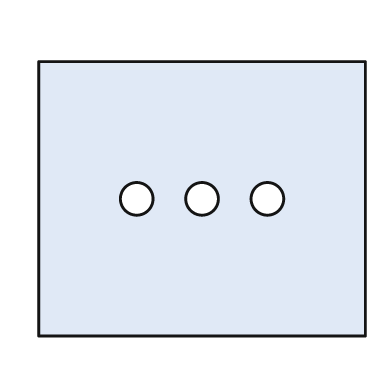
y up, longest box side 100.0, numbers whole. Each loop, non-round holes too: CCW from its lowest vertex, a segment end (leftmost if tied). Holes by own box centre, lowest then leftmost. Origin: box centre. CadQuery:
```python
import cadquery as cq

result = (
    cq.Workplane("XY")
    .moveTo(-50.0, -42.0)
    .lineTo(50.0, -42.0)
    .lineTo(50.0, 42.0)
    .lineTo(-50.0, 42.0)
    .close()
    .moveTo(-20.0, 0.0)
    .circle(5.0)
    .moveTo(0.0, 0.0)
    .circle(5.0)
    .moveTo(20.0, 0.0)
    .circle(5.0)
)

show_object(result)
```